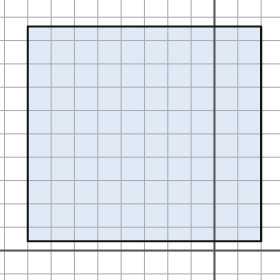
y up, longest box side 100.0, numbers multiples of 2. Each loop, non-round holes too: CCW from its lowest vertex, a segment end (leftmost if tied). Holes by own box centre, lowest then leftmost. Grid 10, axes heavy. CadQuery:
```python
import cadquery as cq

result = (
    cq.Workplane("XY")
    .moveTo(-80.0, 4.0)
    .lineTo(20.0, 4.0)
    .lineTo(20.0, 96.0)
    .lineTo(-80.0, 96.0)
    .close()
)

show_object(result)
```